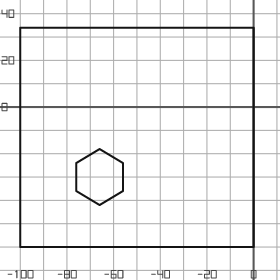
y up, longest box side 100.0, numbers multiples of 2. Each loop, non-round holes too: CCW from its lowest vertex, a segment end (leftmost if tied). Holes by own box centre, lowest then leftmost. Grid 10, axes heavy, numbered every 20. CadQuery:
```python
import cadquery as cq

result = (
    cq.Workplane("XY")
    .moveTo(-100.0, -60.0)
    .lineTo(0.0, -60.0)
    .lineTo(0.0, 34.0)
    .lineTo(-100.0, 34.0)
    .close()
    .moveTo(-66.0, -42.0)
    .lineTo(-56.0, -36.0)
    .lineTo(-56.0, -24.0)
    .lineTo(-66.0, -18.0)
    .lineTo(-76.0, -24.0)
    .lineTo(-76.0, -36.0)
    .close()
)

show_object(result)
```